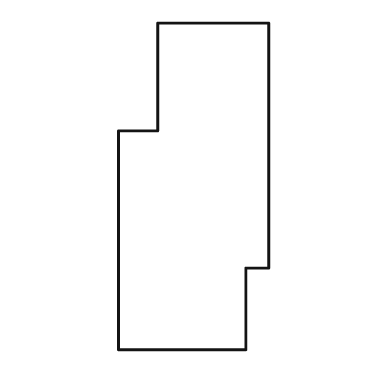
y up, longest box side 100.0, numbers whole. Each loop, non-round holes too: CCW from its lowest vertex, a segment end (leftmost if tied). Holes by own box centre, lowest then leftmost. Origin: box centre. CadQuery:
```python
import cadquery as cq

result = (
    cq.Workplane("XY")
    .moveTo(-23.0, -50.0)
    .lineTo(16.0, -50.0)
    .lineTo(16.0, -25.0)
    .lineTo(23.0, -25.0)
    .lineTo(23.0, 50.0)
    .lineTo(-11.0, 50.0)
    .lineTo(-11.0, 17.0)
    .lineTo(-23.0, 17.0)
    .close()
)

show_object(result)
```